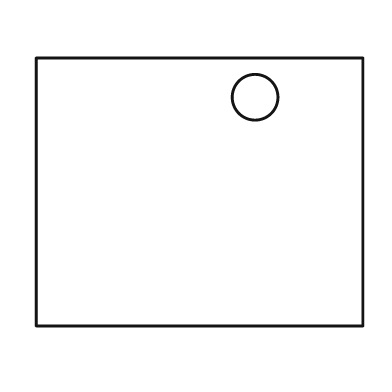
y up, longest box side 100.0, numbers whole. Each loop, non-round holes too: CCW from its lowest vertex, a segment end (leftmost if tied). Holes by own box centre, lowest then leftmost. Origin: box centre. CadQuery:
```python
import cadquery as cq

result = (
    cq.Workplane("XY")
    .moveTo(-50.0, -41.0)
    .lineTo(50.0, -41.0)
    .lineTo(50.0, 41.0)
    .lineTo(-50.0, 41.0)
    .close()
    .moveTo(17.0, 29.0)
    .circle(7.0)
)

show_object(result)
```